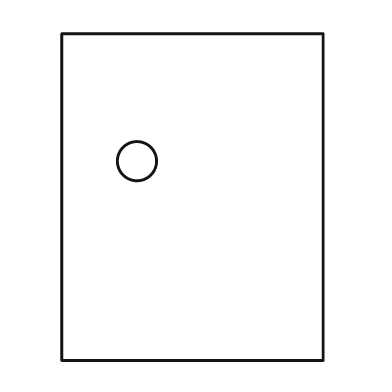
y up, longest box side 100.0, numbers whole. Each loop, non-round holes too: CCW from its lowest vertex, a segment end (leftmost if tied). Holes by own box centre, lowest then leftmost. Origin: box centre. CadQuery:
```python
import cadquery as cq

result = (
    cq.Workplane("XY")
    .moveTo(-40.0, -50.0)
    .lineTo(40.0, -50.0)
    .lineTo(40.0, 50.0)
    .lineTo(-40.0, 50.0)
    .close()
    .moveTo(-17.0, 11.0)
    .circle(6.0)
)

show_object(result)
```